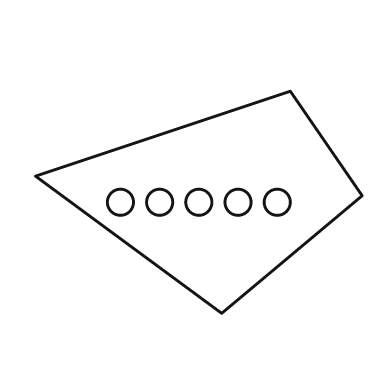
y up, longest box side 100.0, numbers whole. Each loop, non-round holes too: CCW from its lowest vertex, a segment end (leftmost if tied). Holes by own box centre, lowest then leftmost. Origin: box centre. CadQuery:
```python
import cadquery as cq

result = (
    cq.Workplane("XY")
    .moveTo(7.0, -34.0)
    .lineTo(50.0, 2.0)
    .lineTo(28.0, 34.0)
    .lineTo(-50.0, 8.0)
    .close()
    .moveTo(-24.0, 0.0)
    .circle(4.0)
    .moveTo(-12.0, 0.0)
    .circle(4.0)
    .moveTo(0.0, 0.0)
    .circle(4.0)
    .moveTo(12.0, 0.0)
    .circle(4.0)
    .moveTo(24.0, 0.0)
    .circle(4.0)
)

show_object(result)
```